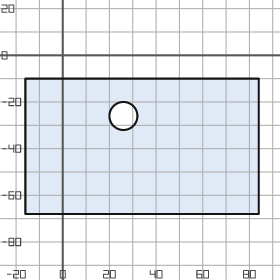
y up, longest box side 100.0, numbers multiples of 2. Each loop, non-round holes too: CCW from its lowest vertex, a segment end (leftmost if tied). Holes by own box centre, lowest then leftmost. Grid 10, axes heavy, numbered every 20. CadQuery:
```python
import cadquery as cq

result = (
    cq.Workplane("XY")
    .moveTo(-16.0, -68.0)
    .lineTo(84.0, -68.0)
    .lineTo(84.0, -10.0)
    .lineTo(-16.0, -10.0)
    .close()
    .moveTo(26.0, -26.0)
    .circle(6.0)
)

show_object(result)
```